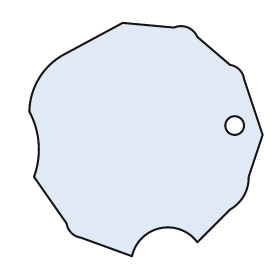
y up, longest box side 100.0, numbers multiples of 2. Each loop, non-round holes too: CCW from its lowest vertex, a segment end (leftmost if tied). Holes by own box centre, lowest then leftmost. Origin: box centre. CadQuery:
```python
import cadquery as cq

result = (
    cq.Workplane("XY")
    .moveTo(-6.0, -50.0)
    .threePointArc((6.0, -38.0), (22.0, -44.0))
    .lineTo(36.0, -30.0)
    .threePointArc((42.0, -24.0), (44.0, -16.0))
    .lineTo(50.0, 2.0)
    .lineTo(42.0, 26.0)
    .threePointArc((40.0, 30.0), (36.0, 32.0))
    .lineTo(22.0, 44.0)
    .threePointArc((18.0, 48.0), (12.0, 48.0))
    .lineTo(-10.0, 50.0)
    .lineTo(-36.0, 36.0)
    .threePointArc((-46.0, 26.0), (-50.0, 12.0))
    .threePointArc((-46.0, -2.0), (-48.0, -16.0))
    .lineTo(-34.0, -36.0)
    .threePointArc((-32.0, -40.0), (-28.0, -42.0))
    .close()
    .moveTo(38.0, 6.0)
    .circle(4.0)
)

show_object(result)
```